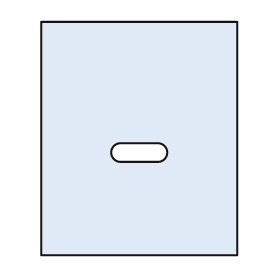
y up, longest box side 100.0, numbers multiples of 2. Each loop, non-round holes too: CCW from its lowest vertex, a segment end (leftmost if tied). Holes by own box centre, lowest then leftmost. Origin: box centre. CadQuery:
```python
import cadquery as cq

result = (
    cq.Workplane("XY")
    .moveTo(-42.0, -50.0)
    .lineTo(42.0, -50.0)
    .lineTo(42.0, 50.0)
    .lineTo(-42.0, 50.0)
    .close()
    .moveTo(-8.0, -10.0)
    .lineTo(8.0, -10.0)
    .threePointArc((12.0, -6.0), (8.0, -2.0))
    .lineTo(-8.0, -2.0)
    .threePointArc((-12.0, -6.0), (-8.0, -10.0))
    .close()
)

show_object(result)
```